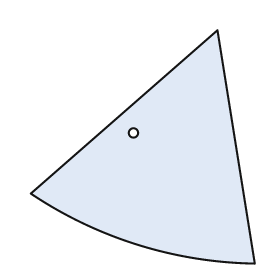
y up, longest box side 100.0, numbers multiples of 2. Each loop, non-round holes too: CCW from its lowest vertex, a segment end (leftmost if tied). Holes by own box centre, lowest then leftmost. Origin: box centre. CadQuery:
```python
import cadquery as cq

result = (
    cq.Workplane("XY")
    .moveTo(48.0, -50.0)
    .lineTo(32.0, 50.0)
    .lineTo(-48.0, -20.0)
    .threePointArc((-2.0, -42.0), (48.0, -50.0))
    .close()
    .moveTo(-4.0, 6.0)
    .circle(2.0)
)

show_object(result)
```